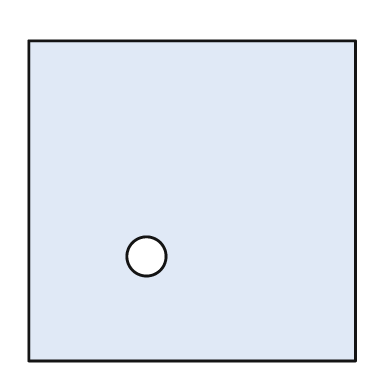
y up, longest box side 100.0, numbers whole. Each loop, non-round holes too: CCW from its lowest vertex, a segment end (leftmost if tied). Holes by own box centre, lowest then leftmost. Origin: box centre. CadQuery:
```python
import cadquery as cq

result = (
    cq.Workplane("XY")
    .moveTo(-50.0, -49.0)
    .lineTo(50.0, -49.0)
    .lineTo(50.0, 49.0)
    .lineTo(-50.0, 49.0)
    .close()
    .moveTo(-14.0, -17.0)
    .circle(6.0)
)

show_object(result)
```